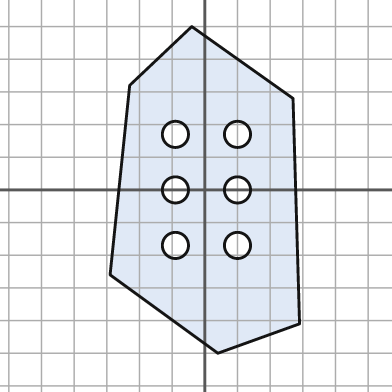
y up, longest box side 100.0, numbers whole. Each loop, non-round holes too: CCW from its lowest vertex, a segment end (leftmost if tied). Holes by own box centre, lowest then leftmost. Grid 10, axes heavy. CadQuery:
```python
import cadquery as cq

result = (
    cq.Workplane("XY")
    .moveTo(4.0, -50.0)
    .lineTo(29.0, -41.0)
    .lineTo(27.0, 28.0)
    .lineTo(-4.0, 50.0)
    .lineTo(-23.0, 32.0)
    .lineTo(-29.0, -26.0)
    .close()
    .moveTo(-9.0, -17.0)
    .circle(4.0)
    .moveTo(10.0, -17.0)
    .circle(4.0)
    .moveTo(-9.0, 0.0)
    .circle(4.0)
    .moveTo(10.0, 0.0)
    .circle(4.0)
    .moveTo(-9.0, 17.0)
    .circle(4.0)
    .moveTo(10.0, 17.0)
    .circle(4.0)
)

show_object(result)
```